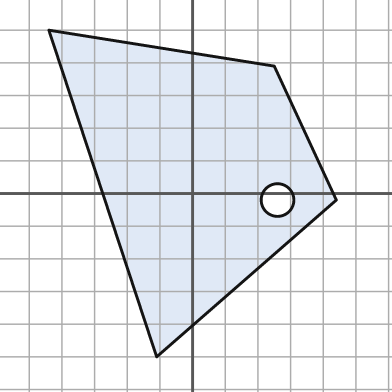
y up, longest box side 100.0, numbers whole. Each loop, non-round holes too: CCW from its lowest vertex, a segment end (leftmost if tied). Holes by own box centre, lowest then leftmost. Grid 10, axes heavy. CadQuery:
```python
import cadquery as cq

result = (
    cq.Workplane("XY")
    .moveTo(-11.0, -50.0)
    .lineTo(44.0, -2.0)
    .lineTo(25.0, 39.0)
    .lineTo(-44.0, 50.0)
    .close()
    .moveTo(26.0, -2.0)
    .circle(5.0)
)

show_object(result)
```